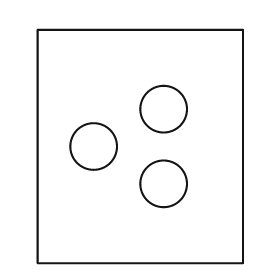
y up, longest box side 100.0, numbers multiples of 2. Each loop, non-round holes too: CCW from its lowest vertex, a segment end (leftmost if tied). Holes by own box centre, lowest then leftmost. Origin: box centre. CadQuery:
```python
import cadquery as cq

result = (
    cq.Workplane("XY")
    .moveTo(-44.0, -50.0)
    .lineTo(44.0, -50.0)
    .lineTo(44.0, 50.0)
    .lineTo(-44.0, 50.0)
    .close()
    .moveTo(10.0, -16.0)
    .circle(10.0)
    .moveTo(-20.0, 0.0)
    .circle(10.0)
    .moveTo(10.0, 16.0)
    .circle(10.0)
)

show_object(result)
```